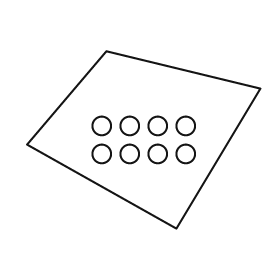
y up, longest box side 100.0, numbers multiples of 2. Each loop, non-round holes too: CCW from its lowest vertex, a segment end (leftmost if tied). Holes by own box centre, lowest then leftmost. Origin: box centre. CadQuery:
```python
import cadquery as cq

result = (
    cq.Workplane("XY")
    .moveTo(14.0, -38.0)
    .lineTo(50.0, 22.0)
    .lineTo(-16.0, 38.0)
    .lineTo(-50.0, -2.0)
    .close()
    .moveTo(-18.0, -6.0)
    .circle(4.0)
    .moveTo(-6.0, -6.0)
    .circle(4.0)
    .moveTo(6.0, -6.0)
    .circle(4.0)
    .moveTo(18.0, -6.0)
    .circle(4.0)
    .moveTo(-18.0, 6.0)
    .circle(4.0)
    .moveTo(-6.0, 6.0)
    .circle(4.0)
    .moveTo(6.0, 6.0)
    .circle(4.0)
    .moveTo(18.0, 6.0)
    .circle(4.0)
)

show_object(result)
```